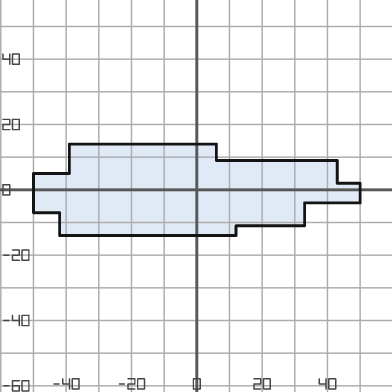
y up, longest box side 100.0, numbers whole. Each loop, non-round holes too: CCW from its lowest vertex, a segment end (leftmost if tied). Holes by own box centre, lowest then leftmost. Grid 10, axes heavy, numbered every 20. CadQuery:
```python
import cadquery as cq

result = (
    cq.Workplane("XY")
    .moveTo(-42.0, -14.0)
    .lineTo(12.0, -14.0)
    .lineTo(12.0, -11.0)
    .lineTo(33.0, -11.0)
    .lineTo(33.0, -4.0)
    .lineTo(50.0, -4.0)
    .lineTo(50.0, 2.0)
    .lineTo(43.0, 2.0)
    .lineTo(43.0, 9.0)
    .lineTo(6.0, 9.0)
    .lineTo(6.0, 14.0)
    .lineTo(-39.0, 14.0)
    .lineTo(-39.0, 5.0)
    .lineTo(-50.0, 5.0)
    .lineTo(-50.0, -7.0)
    .lineTo(-42.0, -7.0)
    .close()
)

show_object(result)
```